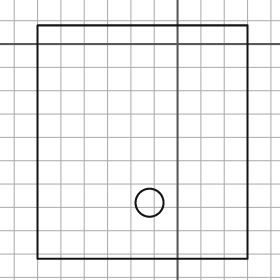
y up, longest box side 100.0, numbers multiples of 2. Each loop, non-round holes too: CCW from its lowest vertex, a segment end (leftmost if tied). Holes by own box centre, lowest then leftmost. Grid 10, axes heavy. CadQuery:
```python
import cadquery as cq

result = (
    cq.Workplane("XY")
    .moveTo(-60.0, -92.0)
    .lineTo(30.0, -92.0)
    .lineTo(30.0, 8.0)
    .lineTo(-60.0, 8.0)
    .close()
    .moveTo(-12.0, -68.0)
    .circle(6.0)
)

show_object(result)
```